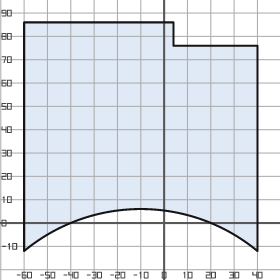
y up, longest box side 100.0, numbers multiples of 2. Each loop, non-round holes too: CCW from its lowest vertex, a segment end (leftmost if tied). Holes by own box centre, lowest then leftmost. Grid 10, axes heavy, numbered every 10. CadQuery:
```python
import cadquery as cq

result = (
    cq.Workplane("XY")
    .moveTo(-60.0, -12.0)
    .threePointArc((-10.0, 6.0), (40.0, -12.0))
    .lineTo(40.0, 76.0)
    .lineTo(4.0, 76.0)
    .lineTo(4.0, 86.0)
    .lineTo(-60.0, 86.0)
    .close()
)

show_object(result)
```